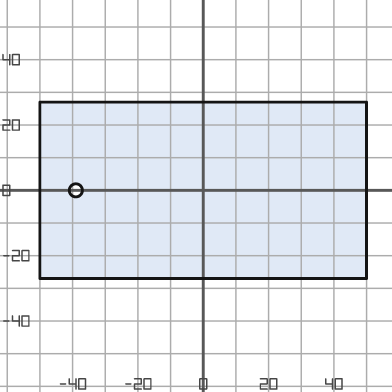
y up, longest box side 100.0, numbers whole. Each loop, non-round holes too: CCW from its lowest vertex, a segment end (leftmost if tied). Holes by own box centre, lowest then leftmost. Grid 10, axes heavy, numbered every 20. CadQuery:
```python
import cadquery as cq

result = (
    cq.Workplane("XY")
    .moveTo(-50.0, -27.0)
    .lineTo(50.0, -27.0)
    .lineTo(50.0, 27.0)
    .lineTo(-50.0, 27.0)
    .close()
    .moveTo(-39.0, 0.0)
    .circle(2.0)
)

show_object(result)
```